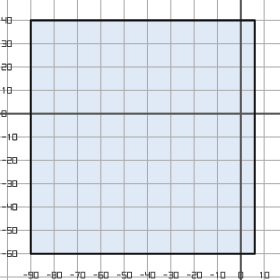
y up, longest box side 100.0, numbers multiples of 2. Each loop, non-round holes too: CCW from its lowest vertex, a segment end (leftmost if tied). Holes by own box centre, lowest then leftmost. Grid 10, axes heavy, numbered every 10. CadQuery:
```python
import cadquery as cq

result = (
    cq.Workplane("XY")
    .moveTo(-90.0, -60.0)
    .lineTo(6.0, -60.0)
    .lineTo(6.0, 40.0)
    .lineTo(-90.0, 40.0)
    .close()
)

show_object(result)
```